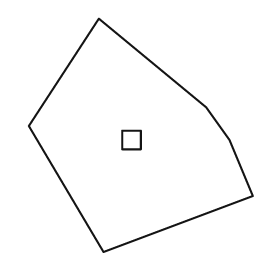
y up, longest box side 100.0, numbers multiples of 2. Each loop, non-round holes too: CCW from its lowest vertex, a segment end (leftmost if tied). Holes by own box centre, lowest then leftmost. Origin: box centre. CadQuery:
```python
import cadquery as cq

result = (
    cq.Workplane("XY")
    .moveTo(-16.0, -50.0)
    .lineTo(48.0, -26.0)
    .lineTo(38.0, -2.0)
    .lineTo(28.0, 12.0)
    .lineTo(-18.0, 50.0)
    .lineTo(-48.0, 4.0)
    .close()
    .moveTo(-8.0, -6.0)
    .lineTo(0.0, -6.0)
    .lineTo(0.0, 2.0)
    .lineTo(-8.0, 2.0)
    .close()
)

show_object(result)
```